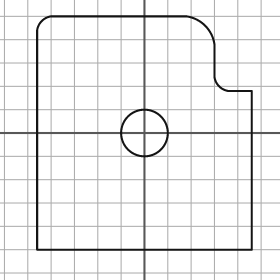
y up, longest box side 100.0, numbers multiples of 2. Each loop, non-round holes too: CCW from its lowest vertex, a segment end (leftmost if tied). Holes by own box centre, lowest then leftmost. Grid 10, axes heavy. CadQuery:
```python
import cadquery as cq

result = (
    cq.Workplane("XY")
    .moveTo(-46.0, -50.0)
    .lineTo(46.0, -50.0)
    .lineTo(46.0, 18.0)
    .lineTo(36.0, 18.0)
    .threePointArc((32.0, 20.0), (30.0, 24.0))
    .lineTo(30.0, 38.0)
    .threePointArc((26.0, 46.0), (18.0, 50.0))
    .lineTo(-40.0, 50.0)
    .threePointArc((-44.0, 48.0), (-46.0, 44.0))
    .close()
    .moveTo(0.0, 0.0)
    .circle(10.0)
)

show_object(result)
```